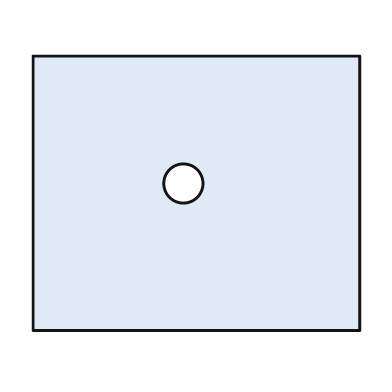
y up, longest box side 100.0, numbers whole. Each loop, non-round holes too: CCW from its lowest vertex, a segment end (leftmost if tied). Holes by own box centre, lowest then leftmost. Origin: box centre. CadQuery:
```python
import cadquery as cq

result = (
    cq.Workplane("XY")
    .moveTo(-50.0, -42.0)
    .lineTo(50.0, -42.0)
    .lineTo(50.0, 42.0)
    .lineTo(-50.0, 42.0)
    .close()
    .moveTo(-4.0, 3.0)
    .circle(6.0)
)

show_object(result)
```